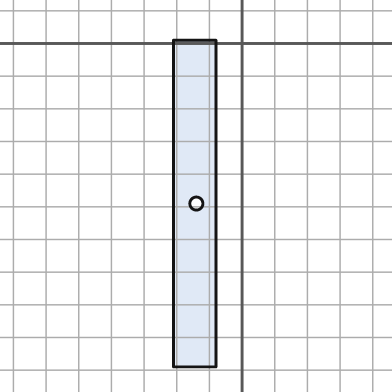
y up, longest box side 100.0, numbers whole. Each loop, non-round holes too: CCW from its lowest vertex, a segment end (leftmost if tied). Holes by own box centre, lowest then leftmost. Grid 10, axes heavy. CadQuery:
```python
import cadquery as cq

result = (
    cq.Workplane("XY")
    .moveTo(-21.0, -99.0)
    .lineTo(-8.0, -99.0)
    .lineTo(-8.0, 1.0)
    .lineTo(-21.0, 1.0)
    .close()
    .moveTo(-14.0, -49.0)
    .circle(2.0)
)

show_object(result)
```